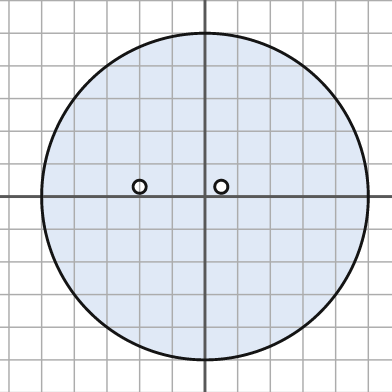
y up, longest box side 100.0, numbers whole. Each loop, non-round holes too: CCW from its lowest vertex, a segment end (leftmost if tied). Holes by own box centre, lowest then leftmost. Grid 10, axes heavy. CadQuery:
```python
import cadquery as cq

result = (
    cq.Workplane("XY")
    .moveTo(0.0, 0.0)
    .circle(50.0)
    .moveTo(-20.0, 3.0)
    .circle(2.0)
    .moveTo(5.0, 3.0)
    .circle(2.0)
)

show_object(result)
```